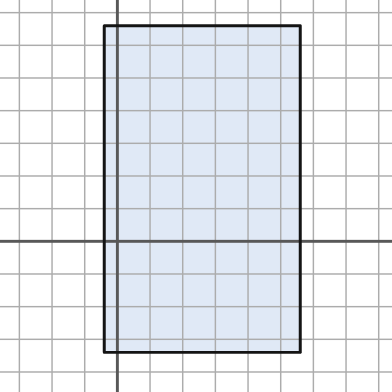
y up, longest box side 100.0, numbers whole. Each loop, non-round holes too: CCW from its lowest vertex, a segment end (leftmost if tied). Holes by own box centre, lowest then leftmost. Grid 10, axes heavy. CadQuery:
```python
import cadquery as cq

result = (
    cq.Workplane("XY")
    .moveTo(-4.0, -34.0)
    .lineTo(56.0, -34.0)
    .lineTo(56.0, 66.0)
    .lineTo(-4.0, 66.0)
    .close()
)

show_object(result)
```